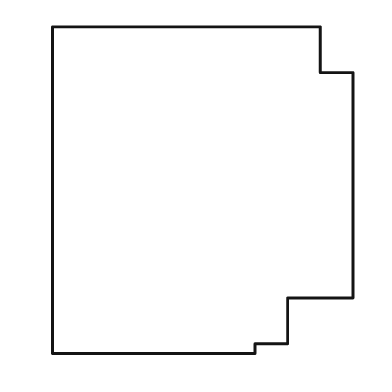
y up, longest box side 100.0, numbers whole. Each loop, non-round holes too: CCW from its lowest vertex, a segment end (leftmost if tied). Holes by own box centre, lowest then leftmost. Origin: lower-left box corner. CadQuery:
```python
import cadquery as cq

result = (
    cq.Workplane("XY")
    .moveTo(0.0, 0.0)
    .lineTo(62.0, 0.0)
    .lineTo(62.0, 3.0)
    .lineTo(72.0, 3.0)
    .lineTo(72.0, 17.0)
    .lineTo(92.0, 17.0)
    .lineTo(92.0, 86.0)
    .lineTo(82.0, 86.0)
    .lineTo(82.0, 100.0)
    .lineTo(0.0, 100.0)
    .close()
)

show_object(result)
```